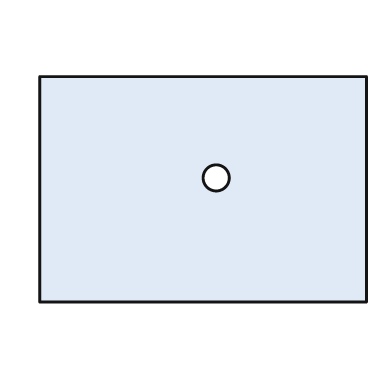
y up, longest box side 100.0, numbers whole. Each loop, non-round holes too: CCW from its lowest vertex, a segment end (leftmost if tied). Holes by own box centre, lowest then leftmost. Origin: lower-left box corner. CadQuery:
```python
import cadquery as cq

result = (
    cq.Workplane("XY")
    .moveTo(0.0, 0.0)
    .lineTo(100.0, 0.0)
    .lineTo(100.0, 69.0)
    .lineTo(0.0, 69.0)
    .close()
    .moveTo(54.0, 38.0)
    .circle(4.0)
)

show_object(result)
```